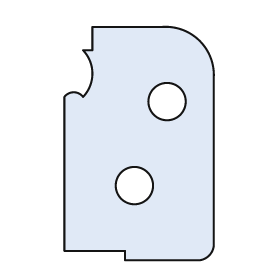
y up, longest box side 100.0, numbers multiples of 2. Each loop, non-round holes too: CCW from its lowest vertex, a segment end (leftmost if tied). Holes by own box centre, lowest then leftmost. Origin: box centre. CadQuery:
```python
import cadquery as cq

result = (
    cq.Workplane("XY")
    .moveTo(-6.0, -50.0)
    .lineTo(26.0, -50.0)
    .threePointArc((30.0, -48.0), (32.0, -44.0))
    .lineTo(32.0, 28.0)
    .threePointArc((26.0, 44.0), (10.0, 50.0))
    .lineTo(-20.0, 50.0)
    .lineTo(-20.0, 40.0)
    .lineTo(-24.0, 40.0)
    .threePointArc((-20.0, 30.0), (-24.0, 20.0))
    .threePointArc((-28.0, 22.0), (-32.0, 20.0))
    .lineTo(-32.0, -46.0)
    .lineTo(-6.0, -46.0)
    .close()
    .moveTo(-2.0, -18.0)
    .circle(8.0)
    .moveTo(12.0, 18.0)
    .circle(8.0)
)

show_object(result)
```